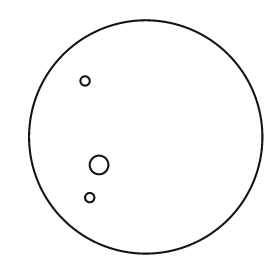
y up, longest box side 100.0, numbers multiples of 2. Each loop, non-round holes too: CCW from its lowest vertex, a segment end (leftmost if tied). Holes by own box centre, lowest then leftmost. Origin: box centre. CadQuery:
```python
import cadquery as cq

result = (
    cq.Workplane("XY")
    .moveTo(0.0, 0.0)
    .circle(50.0)
    .moveTo(-24.0, -26.0)
    .circle(2.0)
    .moveTo(-20.0, -12.0)
    .circle(4.0)
    .moveTo(-26.0, 24.0)
    .circle(2.0)
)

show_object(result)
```